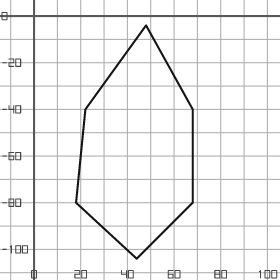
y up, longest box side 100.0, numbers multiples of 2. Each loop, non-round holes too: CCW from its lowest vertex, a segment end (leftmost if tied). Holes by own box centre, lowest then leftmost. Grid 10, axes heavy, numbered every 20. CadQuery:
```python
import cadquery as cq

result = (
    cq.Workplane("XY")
    .moveTo(44.0, -104.0)
    .lineTo(68.0, -80.0)
    .lineTo(68.0, -40.0)
    .lineTo(48.0, -4.0)
    .lineTo(22.0, -40.0)
    .lineTo(18.0, -80.0)
    .close()
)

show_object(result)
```